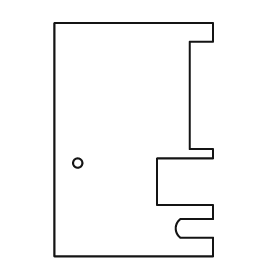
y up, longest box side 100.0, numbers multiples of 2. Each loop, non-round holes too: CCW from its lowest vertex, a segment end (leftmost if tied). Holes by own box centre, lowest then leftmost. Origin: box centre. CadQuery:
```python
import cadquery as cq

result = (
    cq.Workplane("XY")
    .moveTo(-34.0, -50.0)
    .lineTo(34.0, -50.0)
    .lineTo(34.0, -42.0)
    .lineTo(20.0, -42.0)
    .threePointArc((18.0, -38.0), (20.0, -34.0))
    .lineTo(34.0, -34.0)
    .lineTo(34.0, -28.0)
    .lineTo(10.0, -28.0)
    .lineTo(10.0, -8.0)
    .lineTo(34.0, -8.0)
    .lineTo(34.0, -4.0)
    .lineTo(24.0, -4.0)
    .lineTo(24.0, 42.0)
    .lineTo(34.0, 42.0)
    .lineTo(34.0, 50.0)
    .lineTo(-34.0, 50.0)
    .close()
    .moveTo(-24.0, -10.0)
    .circle(2.0)
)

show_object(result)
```